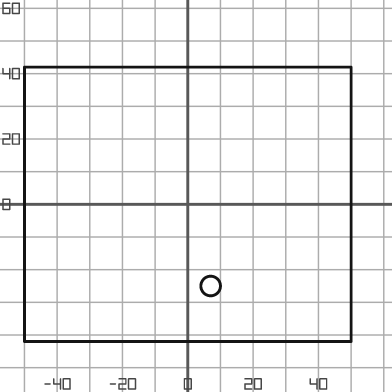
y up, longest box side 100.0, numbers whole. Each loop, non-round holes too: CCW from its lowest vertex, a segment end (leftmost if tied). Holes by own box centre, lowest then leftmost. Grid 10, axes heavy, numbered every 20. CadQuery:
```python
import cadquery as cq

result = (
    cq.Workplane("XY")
    .moveTo(-50.0, -42.0)
    .lineTo(50.0, -42.0)
    .lineTo(50.0, 42.0)
    .lineTo(-50.0, 42.0)
    .close()
    .moveTo(7.0, -25.0)
    .circle(3.0)
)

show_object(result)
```